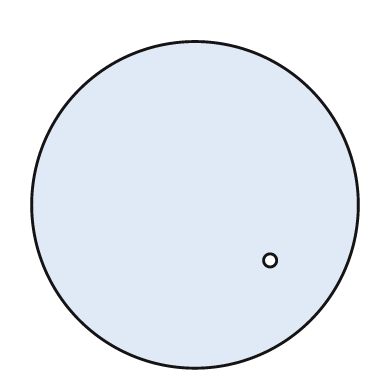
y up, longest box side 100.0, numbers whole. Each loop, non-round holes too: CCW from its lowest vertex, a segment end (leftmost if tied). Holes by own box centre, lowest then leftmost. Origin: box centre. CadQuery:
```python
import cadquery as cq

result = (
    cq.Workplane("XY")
    .moveTo(0.0, 0.0)
    .circle(50.0)
    .moveTo(23.0, -17.0)
    .circle(2.0)
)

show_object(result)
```